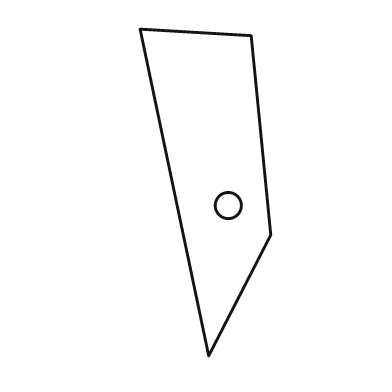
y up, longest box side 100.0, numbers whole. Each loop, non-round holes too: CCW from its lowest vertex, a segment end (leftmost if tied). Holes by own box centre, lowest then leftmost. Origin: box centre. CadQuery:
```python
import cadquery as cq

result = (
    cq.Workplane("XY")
    .moveTo(1.0, -50.0)
    .lineTo(20.0, -13.0)
    .lineTo(14.0, 48.0)
    .lineTo(-20.0, 50.0)
    .close()
    .moveTo(7.0, -4.0)
    .circle(4.0)
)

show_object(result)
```